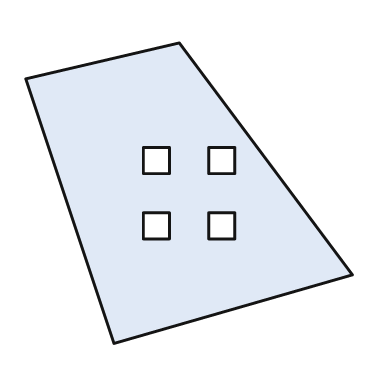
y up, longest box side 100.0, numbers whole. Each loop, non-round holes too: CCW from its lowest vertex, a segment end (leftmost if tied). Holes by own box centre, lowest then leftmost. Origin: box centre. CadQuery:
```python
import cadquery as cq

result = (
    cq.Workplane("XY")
    .moveTo(-23.0, -46.0)
    .lineTo(50.0, -25.0)
    .lineTo(-3.0, 46.0)
    .lineTo(-50.0, 35.0)
    .close()
    .moveTo(-14.0, -14.0)
    .lineTo(-6.0, -14.0)
    .lineTo(-6.0, -6.0)
    .lineTo(-14.0, -6.0)
    .close()
    .moveTo(6.0, -14.0)
    .lineTo(14.0, -14.0)
    .lineTo(14.0, -6.0)
    .lineTo(6.0, -6.0)
    .close()
    .moveTo(-14.0, 6.0)
    .lineTo(-6.0, 6.0)
    .lineTo(-6.0, 14.0)
    .lineTo(-14.0, 14.0)
    .close()
    .moveTo(6.0, 6.0)
    .lineTo(14.0, 6.0)
    .lineTo(14.0, 14.0)
    .lineTo(6.0, 14.0)
    .close()
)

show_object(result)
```